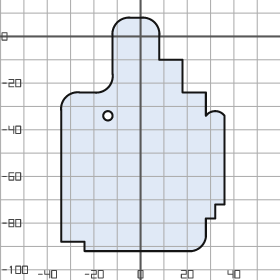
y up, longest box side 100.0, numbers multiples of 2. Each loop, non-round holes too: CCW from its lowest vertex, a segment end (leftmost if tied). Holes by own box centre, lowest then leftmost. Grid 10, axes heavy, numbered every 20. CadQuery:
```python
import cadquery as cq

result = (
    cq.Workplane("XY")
    .moveTo(-24.0, -92.0)
    .lineTo(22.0, -92.0)
    .threePointArc((26.0, -90.0), (28.0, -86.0))
    .lineTo(28.0, -78.0)
    .lineTo(32.0, -78.0)
    .lineTo(32.0, -72.0)
    .lineTo(36.0, -72.0)
    .lineTo(36.0, -34.0)
    .threePointArc((32.0, -32.0), (28.0, -34.0))
    .lineTo(28.0, -24.0)
    .lineTo(18.0, -24.0)
    .lineTo(18.0, -10.0)
    .lineTo(8.0, -10.0)
    .lineTo(8.0, 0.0)
    .threePointArc((6.0, 6.0), (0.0, 8.0))
    .lineTo(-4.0, 8.0)
    .threePointArc((-10.0, 6.0), (-12.0, 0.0))
    .lineTo(-12.0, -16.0)
    .threePointArc((-14.0, -22.0), (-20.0, -24.0))
    .lineTo(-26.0, -24.0)
    .threePointArc((-32.0, -26.0), (-34.0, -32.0))
    .lineTo(-34.0, -88.0)
    .lineTo(-24.0, -88.0)
    .close()
    .moveTo(-14.0, -34.0)
    .circle(2.0)
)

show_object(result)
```